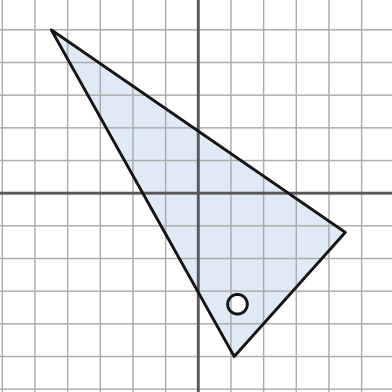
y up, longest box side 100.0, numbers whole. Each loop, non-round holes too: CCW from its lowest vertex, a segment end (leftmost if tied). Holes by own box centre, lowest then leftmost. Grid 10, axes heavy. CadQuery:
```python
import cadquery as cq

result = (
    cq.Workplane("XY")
    .moveTo(11.0, -50.0)
    .lineTo(45.0, -12.0)
    .lineTo(-45.0, 50.0)
    .close()
    .moveTo(12.0, -34.0)
    .circle(3.0)
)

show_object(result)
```